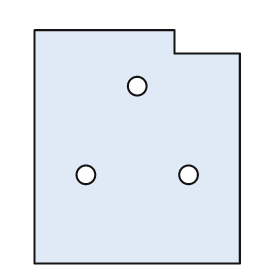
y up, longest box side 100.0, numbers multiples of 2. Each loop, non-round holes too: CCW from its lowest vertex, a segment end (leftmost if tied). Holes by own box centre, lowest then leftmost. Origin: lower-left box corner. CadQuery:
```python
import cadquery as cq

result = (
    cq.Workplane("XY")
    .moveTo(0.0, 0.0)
    .lineTo(88.0, 0.0)
    .lineTo(88.0, 90.0)
    .lineTo(60.0, 90.0)
    .lineTo(60.0, 100.0)
    .lineTo(0.0, 100.0)
    .close()
    .moveTo(22.0, 38.0)
    .circle(4.0)
    .moveTo(66.0, 38.0)
    .circle(4.0)
    .moveTo(44.0, 76.0)
    .circle(4.0)
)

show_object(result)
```